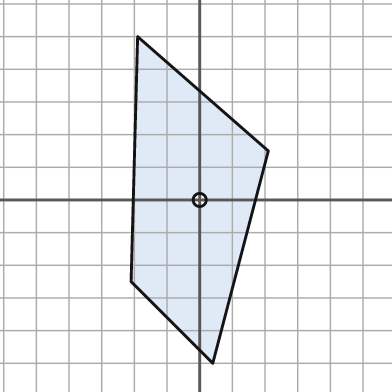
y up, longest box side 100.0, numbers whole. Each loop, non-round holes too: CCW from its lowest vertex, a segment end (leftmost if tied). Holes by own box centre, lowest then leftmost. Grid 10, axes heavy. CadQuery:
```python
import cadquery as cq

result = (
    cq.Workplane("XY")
    .moveTo(4.0, -50.0)
    .lineTo(21.0, 15.0)
    .lineTo(-19.0, 50.0)
    .lineTo(-21.0, -25.0)
    .close()
    .moveTo(0.0, 0.0)
    .circle(2.0)
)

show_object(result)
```